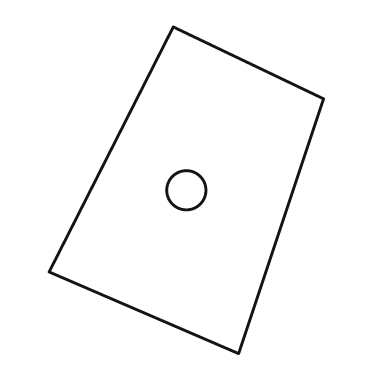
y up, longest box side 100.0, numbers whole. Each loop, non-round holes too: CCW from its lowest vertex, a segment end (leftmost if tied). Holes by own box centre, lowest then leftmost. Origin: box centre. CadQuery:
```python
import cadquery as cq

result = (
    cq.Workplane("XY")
    .moveTo(16.0, -50.0)
    .lineTo(42.0, 28.0)
    .lineTo(-4.0, 50.0)
    .lineTo(-42.0, -25.0)
    .close()
    .moveTo(0.0, 0.0)
    .circle(6.0)
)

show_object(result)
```